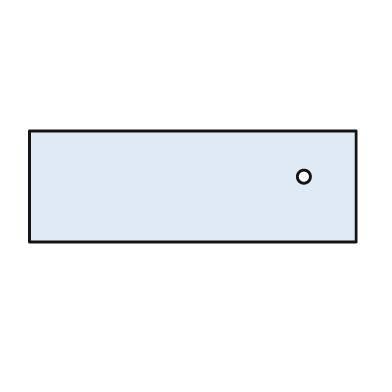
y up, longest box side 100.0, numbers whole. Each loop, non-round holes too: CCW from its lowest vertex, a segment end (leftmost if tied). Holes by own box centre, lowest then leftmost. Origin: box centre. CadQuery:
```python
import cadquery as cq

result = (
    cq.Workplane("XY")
    .moveTo(-50.0, -17.0)
    .lineTo(50.0, -17.0)
    .lineTo(50.0, 17.0)
    .lineTo(-50.0, 17.0)
    .close()
    .moveTo(34.0, 3.0)
    .circle(2.0)
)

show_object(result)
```